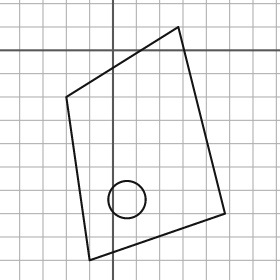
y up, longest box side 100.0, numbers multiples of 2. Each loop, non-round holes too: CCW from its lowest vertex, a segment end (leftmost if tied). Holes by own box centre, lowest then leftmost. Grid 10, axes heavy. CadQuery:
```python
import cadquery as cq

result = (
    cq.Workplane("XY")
    .moveTo(-10.0, -90.0)
    .lineTo(48.0, -70.0)
    .lineTo(28.0, 10.0)
    .lineTo(-20.0, -20.0)
    .close()
    .moveTo(6.0, -64.0)
    .circle(8.0)
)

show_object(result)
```